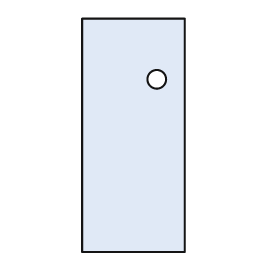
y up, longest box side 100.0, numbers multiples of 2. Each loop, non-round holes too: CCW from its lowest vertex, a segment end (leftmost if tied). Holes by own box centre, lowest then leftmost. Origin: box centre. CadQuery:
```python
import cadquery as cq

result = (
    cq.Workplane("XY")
    .moveTo(-22.0, -50.0)
    .lineTo(22.0, -50.0)
    .lineTo(22.0, 50.0)
    .lineTo(-22.0, 50.0)
    .close()
    .moveTo(10.0, 24.0)
    .circle(4.0)
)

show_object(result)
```